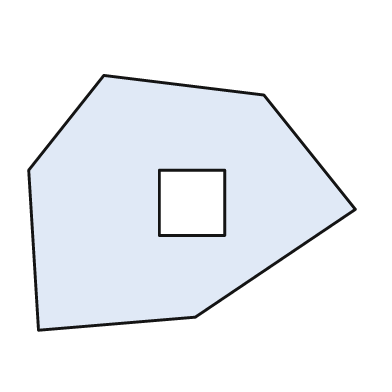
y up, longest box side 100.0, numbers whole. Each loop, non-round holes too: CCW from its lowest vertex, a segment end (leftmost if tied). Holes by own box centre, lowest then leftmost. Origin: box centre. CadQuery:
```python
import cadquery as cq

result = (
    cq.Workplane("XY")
    .moveTo(-47.0, -39.0)
    .lineTo(1.0, -35.0)
    .lineTo(50.0, -2.0)
    .lineTo(22.0, 33.0)
    .lineTo(-27.0, 39.0)
    .lineTo(-50.0, 10.0)
    .close()
    .moveTo(-10.0, -10.0)
    .lineTo(10.0, -10.0)
    .lineTo(10.0, 10.0)
    .lineTo(-10.0, 10.0)
    .close()
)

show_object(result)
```